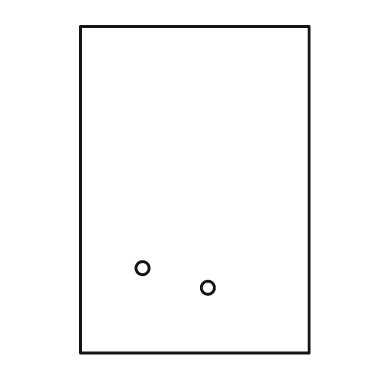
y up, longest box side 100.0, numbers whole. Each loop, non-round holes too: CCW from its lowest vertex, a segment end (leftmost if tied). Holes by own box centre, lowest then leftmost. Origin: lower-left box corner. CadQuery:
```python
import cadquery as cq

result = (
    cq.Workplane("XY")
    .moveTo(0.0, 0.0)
    .lineTo(70.0, 0.0)
    .lineTo(70.0, 100.0)
    .lineTo(0.0, 100.0)
    .close()
    .moveTo(39.0, 20.0)
    .circle(2.0)
    .moveTo(19.0, 26.0)
    .circle(2.0)
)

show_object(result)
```